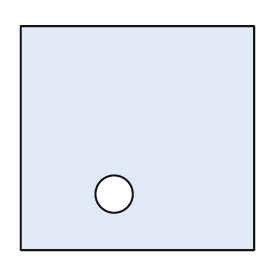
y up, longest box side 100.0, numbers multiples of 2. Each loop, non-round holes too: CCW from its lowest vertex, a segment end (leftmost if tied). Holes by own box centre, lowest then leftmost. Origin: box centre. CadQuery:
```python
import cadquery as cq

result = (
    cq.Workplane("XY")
    .moveTo(-50.0, -48.0)
    .lineTo(50.0, -48.0)
    .lineTo(50.0, 48.0)
    .lineTo(-50.0, 48.0)
    .close()
    .moveTo(-10.0, -24.0)
    .circle(8.0)
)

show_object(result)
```